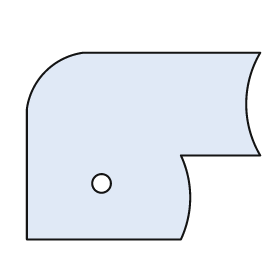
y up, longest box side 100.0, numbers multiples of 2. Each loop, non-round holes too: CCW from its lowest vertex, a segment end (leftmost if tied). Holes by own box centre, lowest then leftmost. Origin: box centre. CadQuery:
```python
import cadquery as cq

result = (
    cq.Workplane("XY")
    .moveTo(-50.0, -40.0)
    .lineTo(16.0, -40.0)
    .threePointArc((20.0, -22.0), (16.0, -4.0))
    .lineTo(50.0, -4.0)
    .threePointArc((44.0, 18.0), (50.0, 40.0))
    .lineTo(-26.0, 40.0)
    .threePointArc((-42.0, 32.0), (-50.0, 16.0))
    .close()
    .moveTo(-18.0, -16.0)
    .circle(4.0)
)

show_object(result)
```